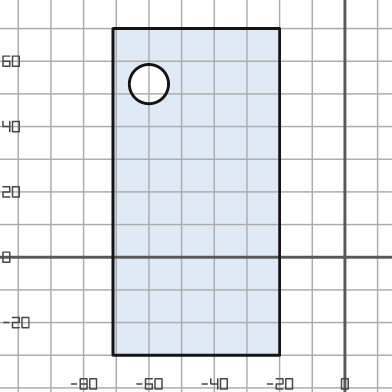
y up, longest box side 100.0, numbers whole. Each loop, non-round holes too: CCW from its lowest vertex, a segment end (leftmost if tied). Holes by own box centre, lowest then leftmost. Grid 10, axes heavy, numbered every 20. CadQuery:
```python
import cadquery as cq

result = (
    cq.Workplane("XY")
    .moveTo(-71.0, -30.0)
    .lineTo(-20.0, -30.0)
    .lineTo(-20.0, 70.0)
    .lineTo(-71.0, 70.0)
    .close()
    .moveTo(-60.0, 53.0)
    .circle(6.0)
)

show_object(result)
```